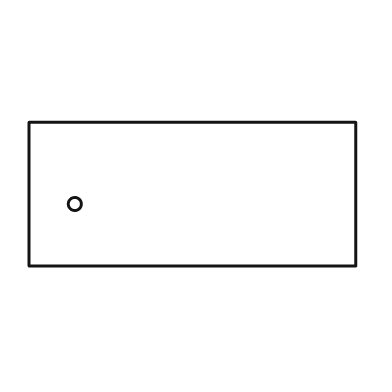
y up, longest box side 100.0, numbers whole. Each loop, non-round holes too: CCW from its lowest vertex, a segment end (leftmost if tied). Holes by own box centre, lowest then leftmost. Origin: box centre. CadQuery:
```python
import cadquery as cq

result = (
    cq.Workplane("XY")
    .moveTo(-50.0, -22.0)
    .lineTo(50.0, -22.0)
    .lineTo(50.0, 22.0)
    .lineTo(-50.0, 22.0)
    .close()
    .moveTo(-36.0, -3.0)
    .circle(2.0)
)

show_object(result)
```